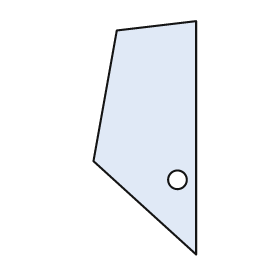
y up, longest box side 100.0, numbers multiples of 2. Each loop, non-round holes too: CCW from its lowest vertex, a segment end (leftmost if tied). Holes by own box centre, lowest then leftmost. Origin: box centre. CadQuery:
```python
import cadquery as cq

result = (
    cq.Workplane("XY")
    .moveTo(22.0, -50.0)
    .lineTo(22.0, 50.0)
    .lineTo(-12.0, 46.0)
    .lineTo(-22.0, -10.0)
    .close()
    .moveTo(14.0, -18.0)
    .circle(4.0)
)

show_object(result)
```